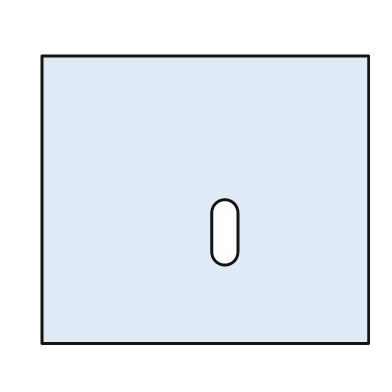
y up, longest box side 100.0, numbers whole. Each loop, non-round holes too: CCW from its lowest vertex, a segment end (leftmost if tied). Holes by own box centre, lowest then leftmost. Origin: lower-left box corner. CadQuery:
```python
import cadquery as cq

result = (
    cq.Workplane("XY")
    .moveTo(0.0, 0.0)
    .lineTo(100.0, 0.0)
    .lineTo(100.0, 88.0)
    .lineTo(0.0, 88.0)
    .close()
    .moveTo(52.0, 28.0)
    .threePointArc((56.0, 24.0), (60.0, 28.0))
    .lineTo(60.0, 40.0)
    .threePointArc((56.0, 44.0), (52.0, 40.0))
    .close()
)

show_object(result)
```